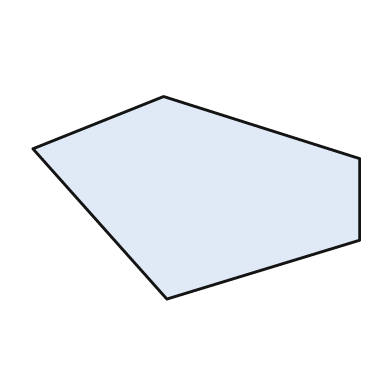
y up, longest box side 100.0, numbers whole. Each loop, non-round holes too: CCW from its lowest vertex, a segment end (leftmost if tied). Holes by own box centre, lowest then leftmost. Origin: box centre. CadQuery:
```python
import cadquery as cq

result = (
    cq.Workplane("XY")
    .moveTo(-9.0, -31.0)
    .lineTo(50.0, -13.0)
    .lineTo(50.0, 12.0)
    .lineTo(-10.0, 31.0)
    .lineTo(-50.0, 15.0)
    .close()
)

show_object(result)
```